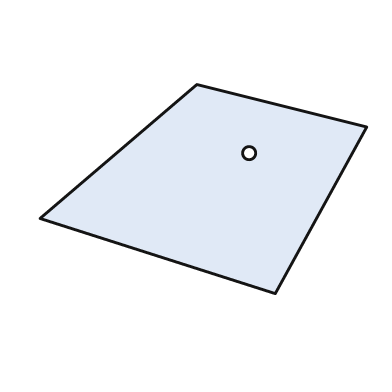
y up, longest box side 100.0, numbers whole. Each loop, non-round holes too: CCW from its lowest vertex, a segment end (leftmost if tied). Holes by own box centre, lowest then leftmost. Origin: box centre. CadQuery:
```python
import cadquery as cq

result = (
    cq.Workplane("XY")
    .moveTo(22.0, -32.0)
    .lineTo(50.0, 19.0)
    .lineTo(-2.0, 32.0)
    .lineTo(-50.0, -9.0)
    .close()
    .moveTo(14.0, 11.0)
    .circle(2.0)
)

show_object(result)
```